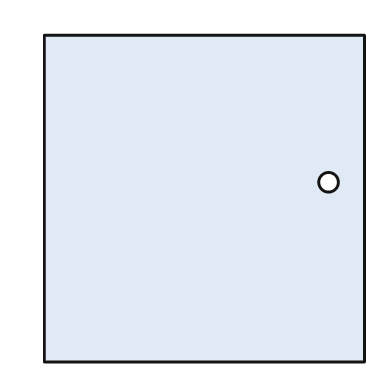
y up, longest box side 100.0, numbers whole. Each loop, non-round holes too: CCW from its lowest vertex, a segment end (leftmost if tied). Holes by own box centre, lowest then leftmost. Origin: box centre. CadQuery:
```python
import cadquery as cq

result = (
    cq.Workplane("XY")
    .moveTo(-49.0, -50.0)
    .lineTo(49.0, -50.0)
    .lineTo(49.0, 50.0)
    .lineTo(-49.0, 50.0)
    .close()
    .moveTo(38.0, 5.0)
    .circle(3.0)
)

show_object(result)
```